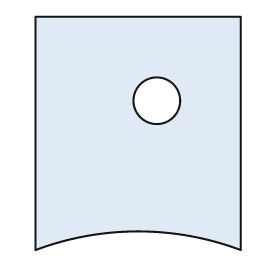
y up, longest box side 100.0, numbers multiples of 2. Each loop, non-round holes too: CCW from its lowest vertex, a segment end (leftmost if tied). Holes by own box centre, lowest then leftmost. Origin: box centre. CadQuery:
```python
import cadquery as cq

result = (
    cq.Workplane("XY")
    .moveTo(-44.0, -50.0)
    .threePointArc((0.0, -42.0), (44.0, -50.0))
    .lineTo(44.0, 50.0)
    .lineTo(-44.0, 50.0)
    .close()
    .moveTo(8.0, 14.0)
    .circle(10.0)
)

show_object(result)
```